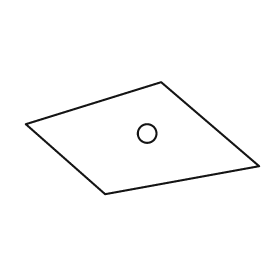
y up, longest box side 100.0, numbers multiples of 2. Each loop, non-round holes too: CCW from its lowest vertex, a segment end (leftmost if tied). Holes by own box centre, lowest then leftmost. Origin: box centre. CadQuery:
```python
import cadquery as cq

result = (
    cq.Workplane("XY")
    .moveTo(-16.0, -24.0)
    .lineTo(50.0, -12.0)
    .lineTo(8.0, 24.0)
    .lineTo(-50.0, 6.0)
    .close()
    .moveTo(2.0, 2.0)
    .circle(4.0)
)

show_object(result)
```